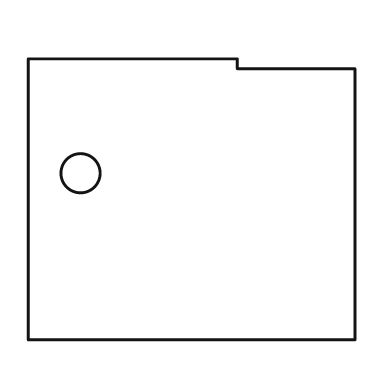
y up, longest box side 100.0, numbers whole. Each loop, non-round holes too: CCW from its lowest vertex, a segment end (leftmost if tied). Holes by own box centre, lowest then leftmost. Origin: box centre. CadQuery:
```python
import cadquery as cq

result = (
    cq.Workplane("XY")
    .moveTo(-50.0, -43.0)
    .lineTo(50.0, -43.0)
    .lineTo(50.0, 40.0)
    .lineTo(14.0, 40.0)
    .lineTo(14.0, 43.0)
    .lineTo(-50.0, 43.0)
    .close()
    .moveTo(-34.0, 8.0)
    .circle(6.0)
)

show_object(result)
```